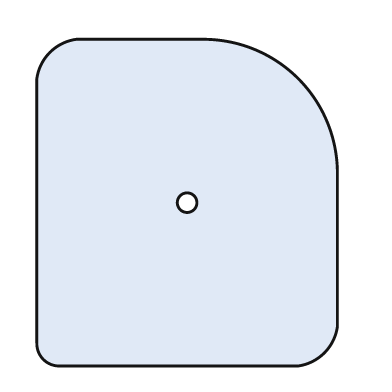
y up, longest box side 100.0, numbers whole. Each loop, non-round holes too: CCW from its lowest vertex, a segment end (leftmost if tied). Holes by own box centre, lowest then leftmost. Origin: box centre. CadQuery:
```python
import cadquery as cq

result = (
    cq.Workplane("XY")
    .moveTo(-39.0, -50.0)
    .lineTo(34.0, -50.0)
    .threePointArc((42.0, -46.0), (46.0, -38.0))
    .lineTo(46.0, 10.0)
    .threePointArc((34.0, 38.0), (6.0, 50.0))
    .lineTo(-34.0, 50.0)
    .threePointArc((-42.0, 46.0), (-46.0, 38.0))
    .lineTo(-46.0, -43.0)
    .threePointArc((-44.0, -48.0), (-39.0, -50.0))
    .close()
    .moveTo(0.0, 0.0)
    .circle(3.0)
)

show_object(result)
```